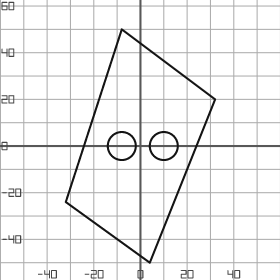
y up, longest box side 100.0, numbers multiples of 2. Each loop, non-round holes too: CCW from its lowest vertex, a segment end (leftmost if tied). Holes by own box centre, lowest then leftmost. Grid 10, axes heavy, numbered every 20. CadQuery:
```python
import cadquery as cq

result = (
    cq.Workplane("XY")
    .moveTo(4.0, -50.0)
    .lineTo(32.0, 20.0)
    .lineTo(-8.0, 50.0)
    .lineTo(-32.0, -24.0)
    .close()
    .moveTo(-8.0, 0.0)
    .circle(6.0)
    .moveTo(10.0, 0.0)
    .circle(6.0)
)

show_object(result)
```